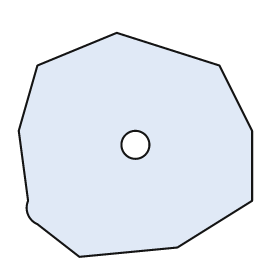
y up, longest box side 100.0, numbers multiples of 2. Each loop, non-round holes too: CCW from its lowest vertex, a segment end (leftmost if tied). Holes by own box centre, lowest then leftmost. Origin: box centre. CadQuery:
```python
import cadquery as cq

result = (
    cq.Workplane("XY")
    .moveTo(-24.0, -48.0)
    .lineTo(18.0, -44.0)
    .lineTo(50.0, -24.0)
    .lineTo(50.0, 6.0)
    .lineTo(36.0, 34.0)
    .lineTo(-8.0, 48.0)
    .lineTo(-42.0, 34.0)
    .lineTo(-50.0, 6.0)
    .lineTo(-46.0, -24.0)
    .threePointArc((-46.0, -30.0), (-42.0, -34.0))
    .close()
    .moveTo(0.0, 0.0)
    .circle(6.0)
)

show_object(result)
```